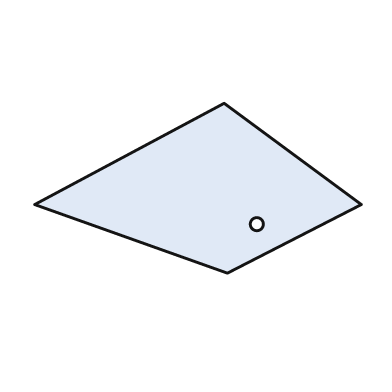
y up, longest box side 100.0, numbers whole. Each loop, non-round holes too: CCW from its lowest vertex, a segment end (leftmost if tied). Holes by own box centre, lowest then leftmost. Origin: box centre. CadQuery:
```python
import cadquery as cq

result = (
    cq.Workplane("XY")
    .moveTo(9.0, -26.0)
    .lineTo(50.0, -5.0)
    .lineTo(8.0, 26.0)
    .lineTo(-50.0, -5.0)
    .close()
    .moveTo(18.0, -11.0)
    .circle(2.0)
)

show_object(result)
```